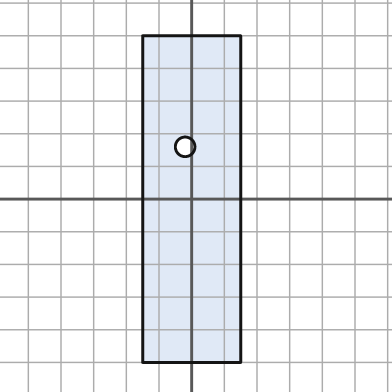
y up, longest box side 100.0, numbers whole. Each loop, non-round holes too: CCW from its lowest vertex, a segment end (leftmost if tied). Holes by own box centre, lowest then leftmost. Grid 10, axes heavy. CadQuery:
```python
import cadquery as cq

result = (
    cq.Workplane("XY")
    .moveTo(-15.0, -50.0)
    .lineTo(15.0, -50.0)
    .lineTo(15.0, 50.0)
    .lineTo(-15.0, 50.0)
    .close()
    .moveTo(-2.0, 16.0)
    .circle(3.0)
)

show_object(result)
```